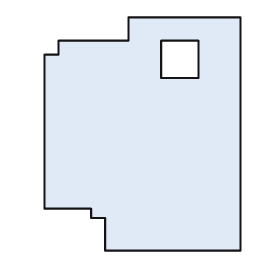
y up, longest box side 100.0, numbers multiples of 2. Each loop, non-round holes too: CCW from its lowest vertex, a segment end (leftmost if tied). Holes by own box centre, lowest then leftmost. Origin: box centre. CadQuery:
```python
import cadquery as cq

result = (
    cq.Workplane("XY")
    .moveTo(-16.0, -50.0)
    .lineTo(42.0, -50.0)
    .lineTo(42.0, 50.0)
    .lineTo(-6.0, 50.0)
    .lineTo(-6.0, 40.0)
    .lineTo(-36.0, 40.0)
    .lineTo(-36.0, 34.0)
    .lineTo(-42.0, 34.0)
    .lineTo(-42.0, -32.0)
    .lineTo(-22.0, -32.0)
    .lineTo(-22.0, -36.0)
    .lineTo(-16.0, -36.0)
    .close()
    .moveTo(8.0, 24.0)
    .lineTo(24.0, 24.0)
    .lineTo(24.0, 40.0)
    .lineTo(8.0, 40.0)
    .close()
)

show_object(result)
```